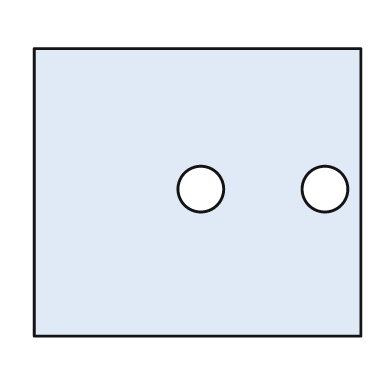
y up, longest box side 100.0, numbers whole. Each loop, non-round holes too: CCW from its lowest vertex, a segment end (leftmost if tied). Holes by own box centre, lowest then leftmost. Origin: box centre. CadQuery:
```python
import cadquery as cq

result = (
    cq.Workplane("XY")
    .moveTo(-50.0, -44.0)
    .lineTo(50.0, -44.0)
    .lineTo(50.0, 44.0)
    .lineTo(-50.0, 44.0)
    .close()
    .moveTo(1.0, 1.0)
    .circle(7.0)
    .moveTo(39.0, 1.0)
    .circle(7.0)
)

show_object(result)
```